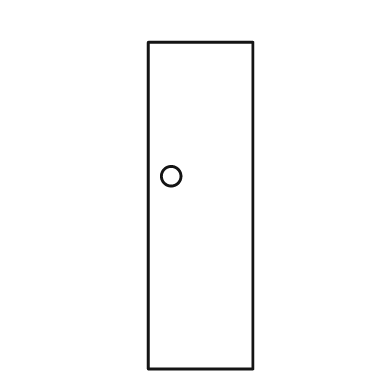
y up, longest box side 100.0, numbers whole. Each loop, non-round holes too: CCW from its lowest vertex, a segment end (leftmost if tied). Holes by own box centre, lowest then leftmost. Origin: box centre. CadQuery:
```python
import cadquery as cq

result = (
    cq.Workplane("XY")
    .moveTo(-16.0, -50.0)
    .lineTo(16.0, -50.0)
    .lineTo(16.0, 50.0)
    .lineTo(-16.0, 50.0)
    .close()
    .moveTo(-9.0, 9.0)
    .circle(3.0)
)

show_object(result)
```